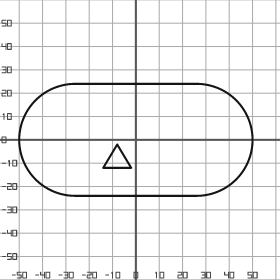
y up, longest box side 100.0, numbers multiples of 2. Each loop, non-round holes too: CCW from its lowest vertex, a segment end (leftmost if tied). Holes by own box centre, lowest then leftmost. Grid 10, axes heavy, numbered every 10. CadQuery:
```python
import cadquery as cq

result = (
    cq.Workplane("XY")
    .moveTo(-26.0, -24.0)
    .lineTo(26.0, -24.0)
    .threePointArc((50.0, 0.0), (26.0, 24.0))
    .lineTo(-26.0, 24.0)
    .threePointArc((-50.0, 0.0), (-26.0, -24.0))
    .close()
    .moveTo(-14.0, -12.0)
    .lineTo(-2.0, -12.0)
    .lineTo(-8.0, -2.0)
    .close()
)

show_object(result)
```